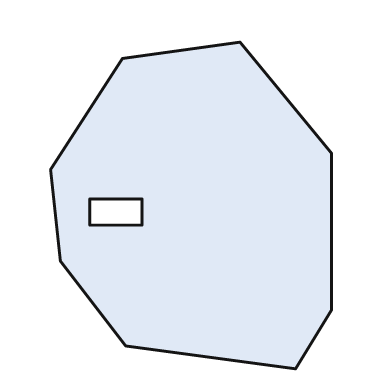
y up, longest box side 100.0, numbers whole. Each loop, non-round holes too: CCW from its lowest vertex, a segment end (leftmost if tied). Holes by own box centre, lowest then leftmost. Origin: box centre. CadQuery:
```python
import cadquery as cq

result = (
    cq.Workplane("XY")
    .moveTo(32.0, -50.0)
    .lineTo(43.0, -32.0)
    .lineTo(43.0, 16.0)
    .lineTo(15.0, 50.0)
    .lineTo(-21.0, 45.0)
    .lineTo(-43.0, 11.0)
    .lineTo(-40.0, -17.0)
    .lineTo(-20.0, -43.0)
    .close()
    .moveTo(-31.0, -6.0)
    .lineTo(-15.0, -6.0)
    .lineTo(-15.0, 2.0)
    .lineTo(-31.0, 2.0)
    .close()
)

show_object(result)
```